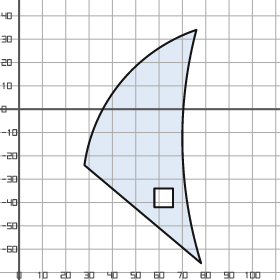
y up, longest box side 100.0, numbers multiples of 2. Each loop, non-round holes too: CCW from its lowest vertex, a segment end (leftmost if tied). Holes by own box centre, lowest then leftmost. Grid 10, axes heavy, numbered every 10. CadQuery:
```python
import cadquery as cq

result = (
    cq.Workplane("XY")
    .moveTo(78.0, -66.0)
    .threePointArc((70.0, -16.0), (76.0, 34.0))
    .threePointArc((44.0, 12.0), (28.0, -24.0))
    .close()
    .moveTo(58.0, -42.0)
    .lineTo(66.0, -42.0)
    .lineTo(66.0, -34.0)
    .lineTo(58.0, -34.0)
    .close()
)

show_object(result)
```